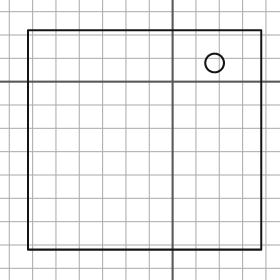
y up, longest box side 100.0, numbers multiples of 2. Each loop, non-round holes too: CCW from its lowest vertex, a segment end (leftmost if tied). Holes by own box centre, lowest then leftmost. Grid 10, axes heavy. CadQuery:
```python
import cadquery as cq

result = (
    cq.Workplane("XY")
    .moveTo(-62.0, -72.0)
    .lineTo(38.0, -72.0)
    .lineTo(38.0, 22.0)
    .lineTo(-62.0, 22.0)
    .close()
    .moveTo(18.0, 8.0)
    .circle(4.0)
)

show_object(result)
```